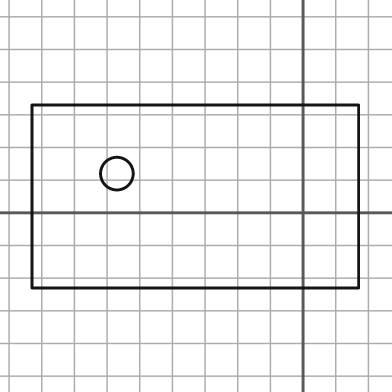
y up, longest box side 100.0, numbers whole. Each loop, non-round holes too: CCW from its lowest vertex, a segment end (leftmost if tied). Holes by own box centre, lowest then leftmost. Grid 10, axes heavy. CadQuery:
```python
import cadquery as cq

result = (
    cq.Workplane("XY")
    .moveTo(-83.0, -23.0)
    .lineTo(17.0, -23.0)
    .lineTo(17.0, 33.0)
    .lineTo(-83.0, 33.0)
    .close()
    .moveTo(-57.0, 12.0)
    .circle(5.0)
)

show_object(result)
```